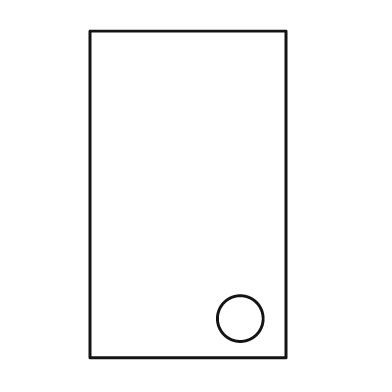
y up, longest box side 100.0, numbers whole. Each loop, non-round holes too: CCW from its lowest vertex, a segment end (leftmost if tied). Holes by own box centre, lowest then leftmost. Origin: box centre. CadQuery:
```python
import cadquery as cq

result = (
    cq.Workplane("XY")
    .moveTo(-30.0, -50.0)
    .lineTo(30.0, -50.0)
    .lineTo(30.0, 50.0)
    .lineTo(-30.0, 50.0)
    .close()
    .moveTo(16.0, -38.0)
    .circle(7.0)
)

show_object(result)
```